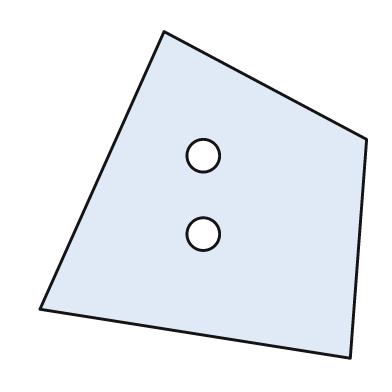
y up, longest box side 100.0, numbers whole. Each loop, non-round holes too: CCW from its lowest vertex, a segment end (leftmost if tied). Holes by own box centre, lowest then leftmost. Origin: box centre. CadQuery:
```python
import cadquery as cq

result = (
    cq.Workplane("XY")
    .moveTo(45.0, -50.0)
    .lineTo(50.0, 17.0)
    .lineTo(-12.0, 50.0)
    .lineTo(-50.0, -35.0)
    .close()
    .moveTo(0.0, -12.0)
    .circle(5.0)
    .moveTo(0.0, 12.0)
    .circle(5.0)
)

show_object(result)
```